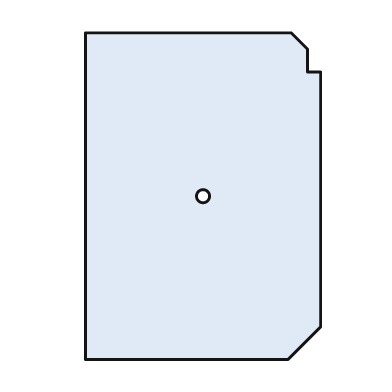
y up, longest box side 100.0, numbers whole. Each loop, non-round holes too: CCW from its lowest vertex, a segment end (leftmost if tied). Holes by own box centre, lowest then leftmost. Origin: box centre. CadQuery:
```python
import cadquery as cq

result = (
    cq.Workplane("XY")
    .moveTo(-36.0, -50.0)
    .lineTo(26.0, -50.0)
    .lineTo(36.0, -40.0)
    .lineTo(36.0, 38.0)
    .lineTo(32.0, 38.0)
    .lineTo(32.0, 45.0)
    .lineTo(27.0, 50.0)
    .lineTo(-36.0, 50.0)
    .close()
    .moveTo(0.0, 0.0)
    .circle(2.0)
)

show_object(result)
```